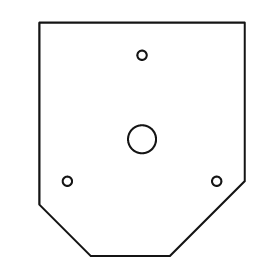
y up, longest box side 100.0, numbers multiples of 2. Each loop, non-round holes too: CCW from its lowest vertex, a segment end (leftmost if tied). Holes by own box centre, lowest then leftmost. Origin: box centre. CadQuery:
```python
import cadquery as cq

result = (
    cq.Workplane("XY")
    .moveTo(-22.0, -50.0)
    .lineTo(12.0, -50.0)
    .lineTo(44.0, -18.0)
    .lineTo(44.0, 50.0)
    .lineTo(-44.0, 50.0)
    .lineTo(-44.0, -28.0)
    .close()
    .moveTo(-32.0, -18.0)
    .circle(2.0)
    .moveTo(32.0, -18.0)
    .circle(2.0)
    .moveTo(0.0, 0.0)
    .circle(6.0)
    .moveTo(0.0, 36.0)
    .circle(2.0)
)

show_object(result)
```